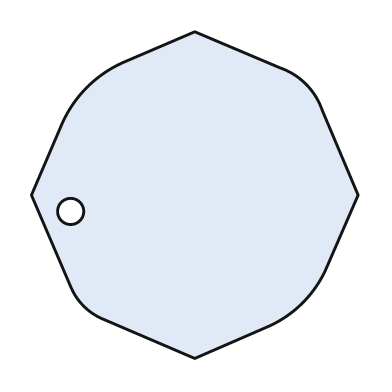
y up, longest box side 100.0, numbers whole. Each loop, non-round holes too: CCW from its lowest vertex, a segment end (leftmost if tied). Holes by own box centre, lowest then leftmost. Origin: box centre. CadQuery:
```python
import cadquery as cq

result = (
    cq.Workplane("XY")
    .moveTo(0.0, -50.0)
    .lineTo(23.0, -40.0)
    .threePointArc((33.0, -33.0), (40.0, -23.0))
    .lineTo(50.0, 0.0)
    .lineTo(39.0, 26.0)
    .threePointArc((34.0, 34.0), (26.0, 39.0))
    .lineTo(0.0, 50.0)
    .lineTo(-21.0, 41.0)
    .threePointArc((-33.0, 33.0), (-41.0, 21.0))
    .lineTo(-50.0, 0.0)
    .lineTo(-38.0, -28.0)
    .threePointArc((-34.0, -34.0), (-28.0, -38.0))
    .close()
    .moveTo(-38.0, -5.0)
    .circle(4.0)
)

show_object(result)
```